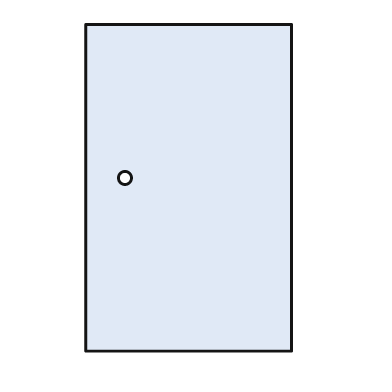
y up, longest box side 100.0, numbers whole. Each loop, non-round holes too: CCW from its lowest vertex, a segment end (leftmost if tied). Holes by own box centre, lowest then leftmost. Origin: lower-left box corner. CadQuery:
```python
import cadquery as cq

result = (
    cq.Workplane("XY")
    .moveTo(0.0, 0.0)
    .lineTo(63.0, 0.0)
    .lineTo(63.0, 100.0)
    .lineTo(0.0, 100.0)
    .close()
    .moveTo(12.0, 53.0)
    .circle(2.0)
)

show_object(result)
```